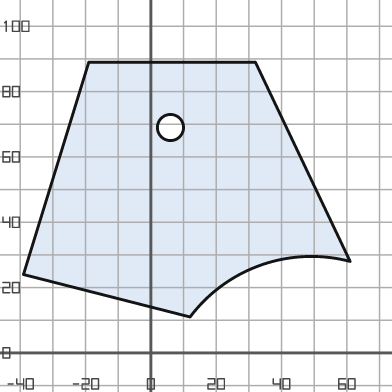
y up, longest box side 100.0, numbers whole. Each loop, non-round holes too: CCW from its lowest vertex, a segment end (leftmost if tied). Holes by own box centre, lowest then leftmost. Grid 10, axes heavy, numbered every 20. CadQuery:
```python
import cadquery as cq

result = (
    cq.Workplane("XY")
    .moveTo(12.0, 11.0)
    .threePointArc((34.0, 27.0), (61.0, 28.0))
    .lineTo(32.0, 89.0)
    .lineTo(-19.0, 89.0)
    .lineTo(-39.0, 24.0)
    .close()
    .moveTo(6.0, 69.0)
    .circle(4.0)
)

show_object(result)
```